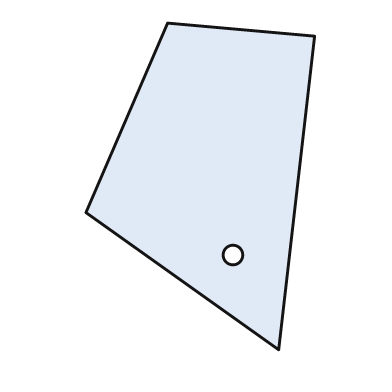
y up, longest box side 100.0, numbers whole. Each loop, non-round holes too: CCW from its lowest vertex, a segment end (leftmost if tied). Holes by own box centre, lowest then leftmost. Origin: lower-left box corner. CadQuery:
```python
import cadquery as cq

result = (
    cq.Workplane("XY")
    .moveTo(59.0, 0.0)
    .lineTo(70.0, 96.0)
    .lineTo(25.0, 100.0)
    .lineTo(0.0, 42.0)
    .close()
    .moveTo(45.0, 29.0)
    .circle(3.0)
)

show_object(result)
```